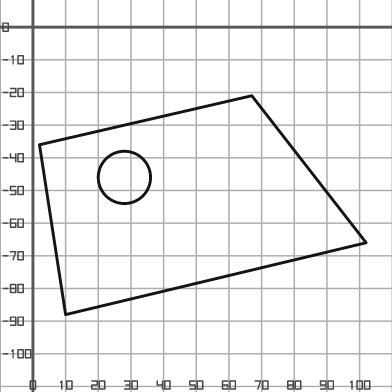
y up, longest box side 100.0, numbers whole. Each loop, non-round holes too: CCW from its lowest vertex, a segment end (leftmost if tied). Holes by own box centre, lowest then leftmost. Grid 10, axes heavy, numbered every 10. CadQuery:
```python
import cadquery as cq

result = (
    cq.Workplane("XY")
    .moveTo(10.0, -88.0)
    .lineTo(102.0, -66.0)
    .lineTo(67.0, -21.0)
    .lineTo(2.0, -36.0)
    .close()
    .moveTo(28.0, -46.0)
    .circle(8.0)
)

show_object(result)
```